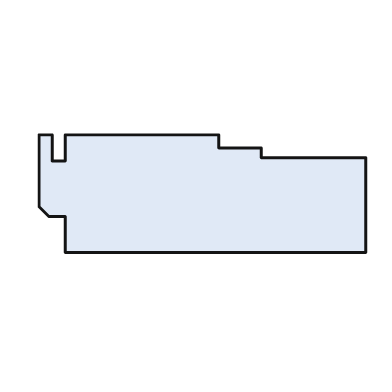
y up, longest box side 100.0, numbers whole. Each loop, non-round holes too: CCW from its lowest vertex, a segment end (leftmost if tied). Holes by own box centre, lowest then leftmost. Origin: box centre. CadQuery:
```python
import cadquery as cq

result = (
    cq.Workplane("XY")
    .moveTo(-42.0, -18.0)
    .lineTo(50.0, -18.0)
    .lineTo(50.0, 11.0)
    .lineTo(18.0, 11.0)
    .lineTo(18.0, 14.0)
    .lineTo(5.0, 14.0)
    .lineTo(5.0, 18.0)
    .lineTo(-42.0, 18.0)
    .lineTo(-42.0, 10.0)
    .lineTo(-46.0, 10.0)
    .lineTo(-46.0, 18.0)
    .lineTo(-50.0, 18.0)
    .lineTo(-50.0, -4.0)
    .lineTo(-47.0, -7.0)
    .lineTo(-42.0, -7.0)
    .close()
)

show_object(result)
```